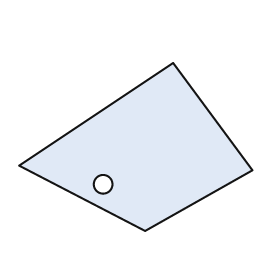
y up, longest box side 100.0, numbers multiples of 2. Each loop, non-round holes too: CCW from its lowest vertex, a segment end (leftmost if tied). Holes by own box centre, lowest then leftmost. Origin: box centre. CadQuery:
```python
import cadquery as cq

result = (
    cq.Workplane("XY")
    .moveTo(4.0, -36.0)
    .lineTo(50.0, -10.0)
    .lineTo(16.0, 36.0)
    .lineTo(-50.0, -8.0)
    .close()
    .moveTo(-14.0, -16.0)
    .circle(4.0)
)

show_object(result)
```